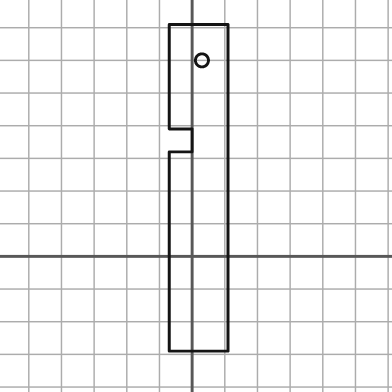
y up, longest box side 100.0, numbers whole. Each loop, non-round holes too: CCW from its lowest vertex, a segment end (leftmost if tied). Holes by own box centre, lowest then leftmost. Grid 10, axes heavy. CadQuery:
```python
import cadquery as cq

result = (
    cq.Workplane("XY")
    .moveTo(-7.0, -29.0)
    .lineTo(11.0, -29.0)
    .lineTo(11.0, 71.0)
    .lineTo(-7.0, 71.0)
    .lineTo(-7.0, 39.0)
    .lineTo(0.0, 39.0)
    .lineTo(0.0, 32.0)
    .lineTo(-7.0, 32.0)
    .close()
    .moveTo(3.0, 60.0)
    .circle(2.0)
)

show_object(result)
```